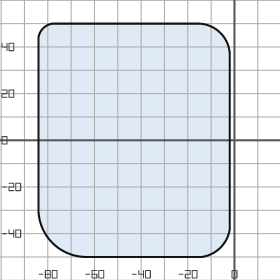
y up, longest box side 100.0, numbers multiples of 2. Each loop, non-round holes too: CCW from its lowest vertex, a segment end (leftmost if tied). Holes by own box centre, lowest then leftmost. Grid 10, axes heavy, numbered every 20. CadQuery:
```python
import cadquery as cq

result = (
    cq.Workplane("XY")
    .moveTo(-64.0, -50.0)
    .lineTo(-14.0, -50.0)
    .threePointArc((-6.0, -46.0), (-2.0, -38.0))
    .lineTo(-2.0, 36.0)
    .threePointArc((-6.0, 46.0), (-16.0, 50.0))
    .lineTo(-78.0, 50.0)
    .threePointArc((-82.0, 48.0), (-84.0, 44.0))
    .lineTo(-84.0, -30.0)
    .threePointArc((-78.0, -44.0), (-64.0, -50.0))
    .close()
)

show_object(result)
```